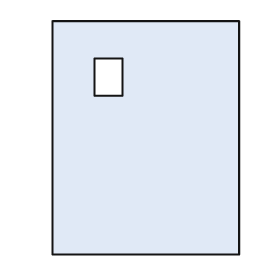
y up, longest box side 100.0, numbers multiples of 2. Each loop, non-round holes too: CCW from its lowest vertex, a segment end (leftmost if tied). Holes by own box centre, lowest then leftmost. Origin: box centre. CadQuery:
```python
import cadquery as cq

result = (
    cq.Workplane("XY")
    .moveTo(-40.0, -50.0)
    .lineTo(40.0, -50.0)
    .lineTo(40.0, 50.0)
    .lineTo(-40.0, 50.0)
    .close()
    .moveTo(-22.0, 18.0)
    .lineTo(-10.0, 18.0)
    .lineTo(-10.0, 34.0)
    .lineTo(-22.0, 34.0)
    .close()
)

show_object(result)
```